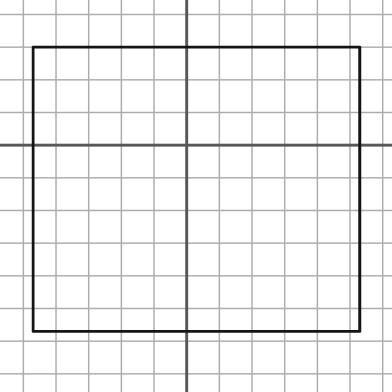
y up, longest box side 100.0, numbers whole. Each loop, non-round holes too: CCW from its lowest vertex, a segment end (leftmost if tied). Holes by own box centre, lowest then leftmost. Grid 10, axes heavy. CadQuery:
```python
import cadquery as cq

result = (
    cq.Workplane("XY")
    .moveTo(-47.0, -57.0)
    .lineTo(53.0, -57.0)
    .lineTo(53.0, 30.0)
    .lineTo(-47.0, 30.0)
    .close()
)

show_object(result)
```